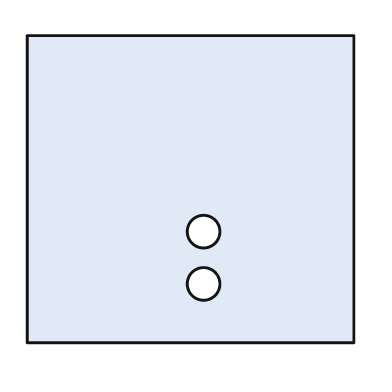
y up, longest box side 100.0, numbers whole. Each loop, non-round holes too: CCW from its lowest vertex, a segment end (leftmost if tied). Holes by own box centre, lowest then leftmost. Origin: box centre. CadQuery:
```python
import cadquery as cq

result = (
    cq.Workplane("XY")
    .moveTo(-50.0, -47.0)
    .lineTo(50.0, -47.0)
    .lineTo(50.0, 47.0)
    .lineTo(-50.0, 47.0)
    .close()
    .moveTo(4.0, -29.0)
    .circle(5.0)
    .moveTo(4.0, -13.0)
    .circle(5.0)
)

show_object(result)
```